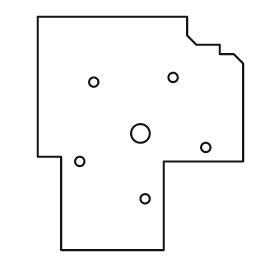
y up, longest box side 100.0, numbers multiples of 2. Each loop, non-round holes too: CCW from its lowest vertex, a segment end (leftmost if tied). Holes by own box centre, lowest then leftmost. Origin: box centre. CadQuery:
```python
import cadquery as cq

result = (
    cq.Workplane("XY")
    .moveTo(-34.0, -50.0)
    .lineTo(10.0, -50.0)
    .lineTo(10.0, -12.0)
    .lineTo(44.0, -12.0)
    .lineTo(44.0, 30.0)
    .lineTo(40.0, 34.0)
    .lineTo(34.0, 34.0)
    .lineTo(34.0, 38.0)
    .lineTo(24.0, 38.0)
    .lineTo(20.0, 42.0)
    .lineTo(20.0, 50.0)
    .lineTo(-44.0, 50.0)
    .lineTo(-44.0, -10.0)
    .lineTo(-34.0, -10.0)
    .close()
    .moveTo(2.0, -28.0)
    .circle(2.0)
    .moveTo(-26.0, -12.0)
    .circle(2.0)
    .moveTo(28.0, -6.0)
    .circle(2.0)
    .moveTo(0.0, 0.0)
    .circle(4.0)
    .moveTo(-20.0, 22.0)
    .circle(2.0)
    .moveTo(14.0, 24.0)
    .circle(2.0)
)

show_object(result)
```